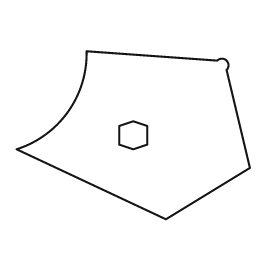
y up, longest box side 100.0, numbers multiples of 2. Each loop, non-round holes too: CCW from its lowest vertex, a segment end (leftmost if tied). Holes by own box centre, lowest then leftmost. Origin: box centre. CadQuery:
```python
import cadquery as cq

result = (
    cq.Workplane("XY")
    .moveTo(14.0, -36.0)
    .lineTo(50.0, -14.0)
    .lineTo(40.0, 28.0)
    .threePointArc((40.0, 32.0), (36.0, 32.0))
    .lineTo(-20.0, 36.0)
    .threePointArc((-28.0, 10.0), (-50.0, -6.0))
    .close()
    .moveTo(0.0, -6.0)
    .lineTo(6.0, -4.0)
    .lineTo(6.0, 4.0)
    .lineTo(0.0, 6.0)
    .lineTo(-6.0, 4.0)
    .lineTo(-6.0, -4.0)
    .close()
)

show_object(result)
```